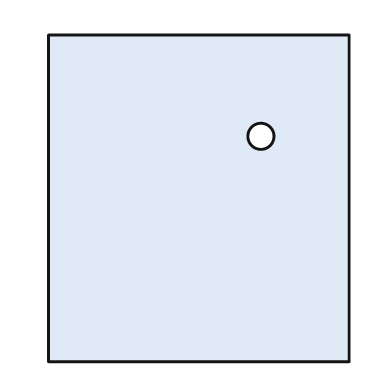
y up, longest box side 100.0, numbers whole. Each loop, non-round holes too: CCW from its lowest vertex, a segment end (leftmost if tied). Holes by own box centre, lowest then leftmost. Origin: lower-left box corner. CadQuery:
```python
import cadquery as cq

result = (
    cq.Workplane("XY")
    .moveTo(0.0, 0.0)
    .lineTo(92.0, 0.0)
    .lineTo(92.0, 100.0)
    .lineTo(0.0, 100.0)
    .close()
    .moveTo(65.0, 69.0)
    .circle(4.0)
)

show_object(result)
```